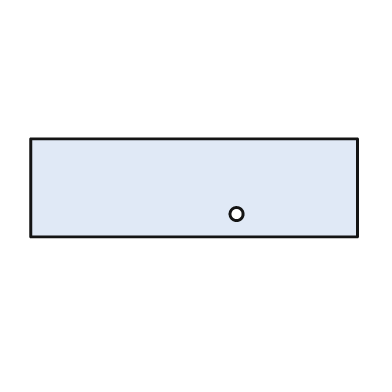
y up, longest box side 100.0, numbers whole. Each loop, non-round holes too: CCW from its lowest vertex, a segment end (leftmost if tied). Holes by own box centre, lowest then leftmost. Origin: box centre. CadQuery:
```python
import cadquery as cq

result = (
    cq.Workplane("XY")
    .moveTo(-50.0, -15.0)
    .lineTo(50.0, -15.0)
    .lineTo(50.0, 15.0)
    .lineTo(-50.0, 15.0)
    .close()
    .moveTo(13.0, -8.0)
    .circle(2.0)
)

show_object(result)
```